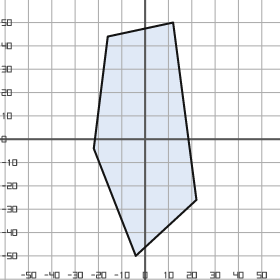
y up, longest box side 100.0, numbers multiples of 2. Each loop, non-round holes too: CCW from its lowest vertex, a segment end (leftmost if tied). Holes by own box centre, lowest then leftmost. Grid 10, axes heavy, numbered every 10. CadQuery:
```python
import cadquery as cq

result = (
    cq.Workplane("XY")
    .moveTo(-4.0, -50.0)
    .lineTo(22.0, -26.0)
    .lineTo(12.0, 50.0)
    .lineTo(-16.0, 44.0)
    .lineTo(-22.0, -4.0)
    .close()
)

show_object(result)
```